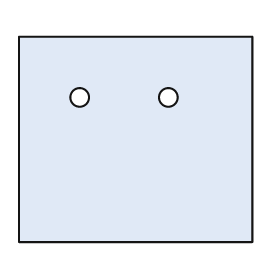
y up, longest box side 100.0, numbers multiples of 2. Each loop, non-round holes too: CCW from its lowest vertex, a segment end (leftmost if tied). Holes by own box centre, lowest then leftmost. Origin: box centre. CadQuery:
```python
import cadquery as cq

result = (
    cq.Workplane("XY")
    .moveTo(-50.0, -44.0)
    .lineTo(50.0, -44.0)
    .lineTo(50.0, 44.0)
    .lineTo(-50.0, 44.0)
    .close()
    .moveTo(-24.0, 18.0)
    .circle(4.0)
    .moveTo(14.0, 18.0)
    .circle(4.0)
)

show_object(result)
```